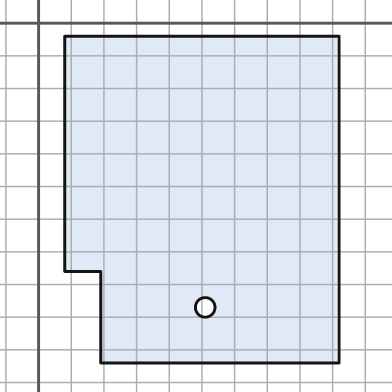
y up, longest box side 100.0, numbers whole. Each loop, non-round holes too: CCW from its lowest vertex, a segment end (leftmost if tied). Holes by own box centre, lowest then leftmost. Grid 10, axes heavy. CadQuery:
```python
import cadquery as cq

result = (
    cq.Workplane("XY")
    .moveTo(19.0, -104.0)
    .lineTo(92.0, -104.0)
    .lineTo(92.0, -4.0)
    .lineTo(8.0, -4.0)
    .lineTo(8.0, -76.0)
    .lineTo(19.0, -76.0)
    .close()
    .moveTo(51.0, -87.0)
    .circle(3.0)
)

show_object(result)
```